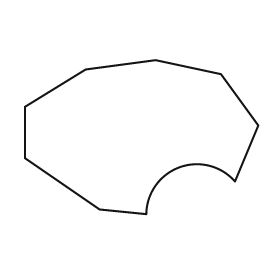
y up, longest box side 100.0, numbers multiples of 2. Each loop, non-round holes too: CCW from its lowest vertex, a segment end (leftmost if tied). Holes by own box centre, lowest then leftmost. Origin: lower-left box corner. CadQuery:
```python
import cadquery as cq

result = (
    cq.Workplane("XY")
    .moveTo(52.0, 0.0)
    .threePointArc((66.0, 20.0), (90.0, 14.0))
    .lineTo(100.0, 38.0)
    .lineTo(84.0, 60.0)
    .lineTo(56.0, 66.0)
    .lineTo(26.0, 62.0)
    .lineTo(0.0, 46.0)
    .lineTo(0.0, 24.0)
    .lineTo(32.0, 2.0)
    .close()
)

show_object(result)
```